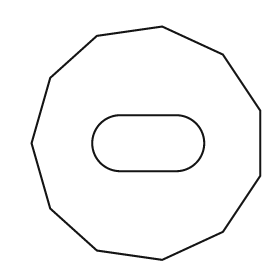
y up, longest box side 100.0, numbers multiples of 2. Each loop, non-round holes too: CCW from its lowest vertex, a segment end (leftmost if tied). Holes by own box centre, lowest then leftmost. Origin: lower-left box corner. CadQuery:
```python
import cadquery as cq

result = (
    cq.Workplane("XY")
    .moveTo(56.0, 0.0)
    .lineTo(82.0, 12.0)
    .lineTo(98.0, 36.0)
    .lineTo(98.0, 64.0)
    .lineTo(82.0, 88.0)
    .lineTo(56.0, 100.0)
    .lineTo(28.0, 96.0)
    .lineTo(8.0, 78.0)
    .lineTo(0.0, 50.0)
    .lineTo(8.0, 22.0)
    .lineTo(28.0, 4.0)
    .close()
    .moveTo(38.0, 38.0)
    .lineTo(62.0, 38.0)
    .threePointArc((74.0, 50.0), (62.0, 62.0))
    .lineTo(38.0, 62.0)
    .threePointArc((26.0, 50.0), (38.0, 38.0))
    .close()
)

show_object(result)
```